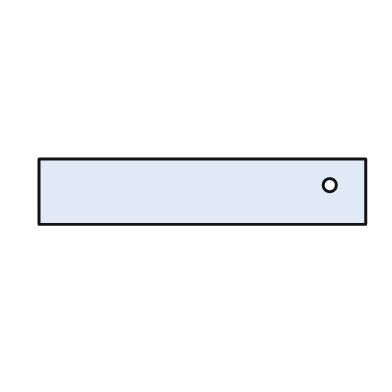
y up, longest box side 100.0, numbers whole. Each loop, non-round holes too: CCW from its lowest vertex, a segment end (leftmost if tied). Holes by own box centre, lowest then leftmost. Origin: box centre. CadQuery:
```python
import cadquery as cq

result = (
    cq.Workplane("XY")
    .moveTo(-50.0, -10.0)
    .lineTo(50.0, -10.0)
    .lineTo(50.0, 10.0)
    .lineTo(-50.0, 10.0)
    .close()
    .moveTo(39.0, 2.0)
    .circle(2.0)
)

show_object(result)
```